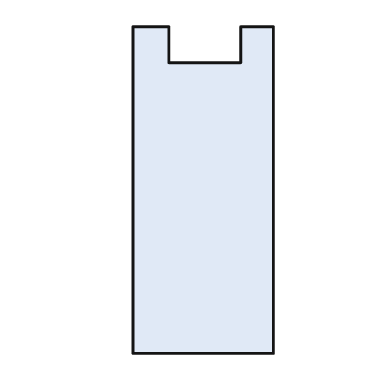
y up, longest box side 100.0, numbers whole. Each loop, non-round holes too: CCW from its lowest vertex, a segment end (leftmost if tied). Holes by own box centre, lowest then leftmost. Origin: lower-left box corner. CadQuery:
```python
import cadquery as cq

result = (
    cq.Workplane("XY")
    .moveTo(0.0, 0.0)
    .lineTo(43.0, 0.0)
    .lineTo(43.0, 100.0)
    .lineTo(33.0, 100.0)
    .lineTo(33.0, 89.0)
    .lineTo(11.0, 89.0)
    .lineTo(11.0, 100.0)
    .lineTo(0.0, 100.0)
    .close()
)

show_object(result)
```